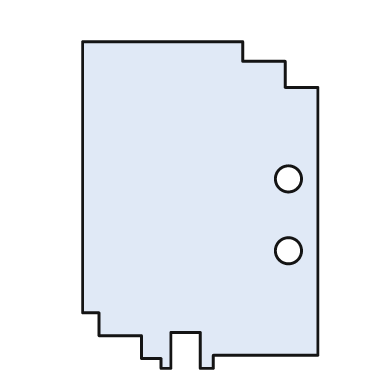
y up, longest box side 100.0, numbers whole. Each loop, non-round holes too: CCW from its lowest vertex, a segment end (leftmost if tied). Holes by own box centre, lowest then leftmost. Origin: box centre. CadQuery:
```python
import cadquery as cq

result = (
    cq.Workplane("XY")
    .moveTo(-12.0, -50.0)
    .lineTo(-9.0, -50.0)
    .lineTo(-9.0, -39.0)
    .lineTo(0.0, -39.0)
    .lineTo(0.0, -50.0)
    .lineTo(4.0, -50.0)
    .lineTo(4.0, -46.0)
    .lineTo(36.0, -46.0)
    .lineTo(36.0, 36.0)
    .lineTo(26.0, 36.0)
    .lineTo(26.0, 44.0)
    .lineTo(13.0, 44.0)
    .lineTo(13.0, 50.0)
    .lineTo(-36.0, 50.0)
    .lineTo(-36.0, -33.0)
    .lineTo(-31.0, -33.0)
    .lineTo(-31.0, -40.0)
    .lineTo(-18.0, -40.0)
    .lineTo(-18.0, -47.0)
    .lineTo(-12.0, -47.0)
    .close()
    .moveTo(27.0, -14.0)
    .circle(4.0)
    .moveTo(27.0, 8.0)
    .circle(4.0)
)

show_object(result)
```